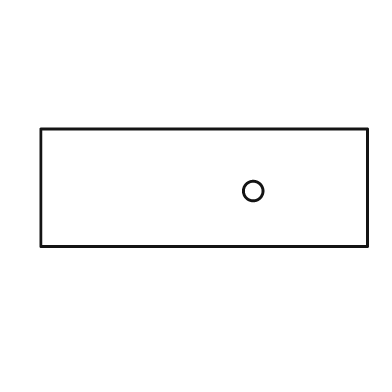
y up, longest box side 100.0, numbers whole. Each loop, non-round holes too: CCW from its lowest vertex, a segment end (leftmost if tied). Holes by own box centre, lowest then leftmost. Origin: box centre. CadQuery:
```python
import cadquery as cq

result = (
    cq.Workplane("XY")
    .moveTo(-50.0, -18.0)
    .lineTo(50.0, -18.0)
    .lineTo(50.0, 18.0)
    .lineTo(-50.0, 18.0)
    .close()
    .moveTo(15.0, -1.0)
    .circle(3.0)
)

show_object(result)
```